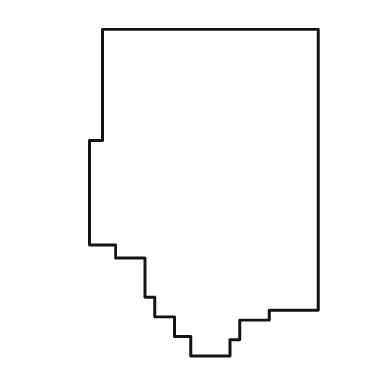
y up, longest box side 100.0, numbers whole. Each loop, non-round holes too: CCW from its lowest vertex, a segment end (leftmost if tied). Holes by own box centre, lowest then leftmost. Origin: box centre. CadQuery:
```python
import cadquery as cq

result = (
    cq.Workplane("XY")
    .moveTo(-4.0, -50.0)
    .lineTo(8.0, -50.0)
    .lineTo(8.0, -45.0)
    .lineTo(11.0, -45.0)
    .lineTo(11.0, -39.0)
    .lineTo(20.0, -39.0)
    .lineTo(20.0, -36.0)
    .lineTo(35.0, -36.0)
    .lineTo(35.0, 50.0)
    .lineTo(-31.0, 50.0)
    .lineTo(-31.0, 16.0)
    .lineTo(-35.0, 16.0)
    .lineTo(-35.0, -16.0)
    .lineTo(-27.0, -16.0)
    .lineTo(-27.0, -20.0)
    .lineTo(-18.0, -20.0)
    .lineTo(-18.0, -32.0)
    .lineTo(-15.0, -32.0)
    .lineTo(-15.0, -38.0)
    .lineTo(-9.0, -38.0)
    .lineTo(-9.0, -44.0)
    .lineTo(-4.0, -44.0)
    .close()
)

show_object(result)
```